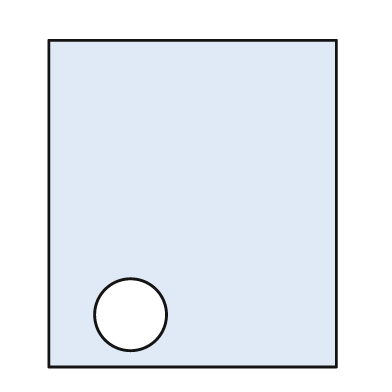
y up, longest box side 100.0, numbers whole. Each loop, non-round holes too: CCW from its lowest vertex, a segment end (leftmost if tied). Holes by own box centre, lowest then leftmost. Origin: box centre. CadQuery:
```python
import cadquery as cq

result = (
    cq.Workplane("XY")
    .moveTo(-44.0, -50.0)
    .lineTo(44.0, -50.0)
    .lineTo(44.0, 50.0)
    .lineTo(-44.0, 50.0)
    .close()
    .moveTo(-19.0, -34.0)
    .circle(11.0)
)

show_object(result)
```